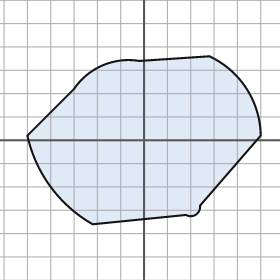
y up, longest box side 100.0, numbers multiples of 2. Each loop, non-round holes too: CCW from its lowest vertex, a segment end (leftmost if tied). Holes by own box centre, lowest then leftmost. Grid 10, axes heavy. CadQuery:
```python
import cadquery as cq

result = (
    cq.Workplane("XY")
    .moveTo(-22.0, -36.0)
    .lineTo(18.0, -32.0)
    .threePointArc((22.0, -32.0), (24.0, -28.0))
    .lineTo(50.0, 2.0)
    .threePointArc((44.0, 22.0), (28.0, 36.0))
    .lineTo(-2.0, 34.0)
    .threePointArc((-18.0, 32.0), (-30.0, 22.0))
    .lineTo(-50.0, 2.0)
    .threePointArc((-40.0, -20.0), (-22.0, -36.0))
    .close()
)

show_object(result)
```